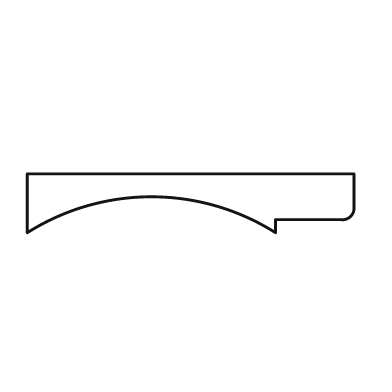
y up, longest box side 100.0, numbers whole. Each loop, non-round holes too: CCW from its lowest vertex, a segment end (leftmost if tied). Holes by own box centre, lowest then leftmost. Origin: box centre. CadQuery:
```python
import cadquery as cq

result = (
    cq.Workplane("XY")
    .moveTo(-50.0, -9.0)
    .threePointArc((-12.0, 2.0), (26.0, -9.0))
    .lineTo(26.0, -5.0)
    .lineTo(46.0, -5.0)
    .threePointArc((49.0, -4.0), (50.0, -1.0))
    .lineTo(50.0, 9.0)
    .lineTo(-50.0, 9.0)
    .close()
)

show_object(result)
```